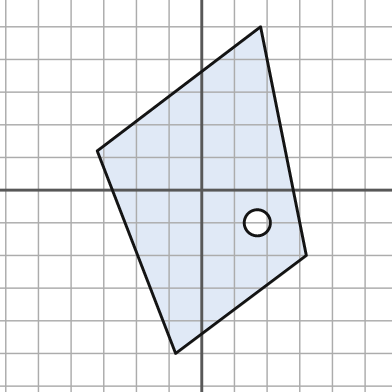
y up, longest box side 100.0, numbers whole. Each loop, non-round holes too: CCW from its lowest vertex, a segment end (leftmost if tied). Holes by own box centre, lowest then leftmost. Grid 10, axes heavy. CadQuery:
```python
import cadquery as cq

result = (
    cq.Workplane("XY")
    .moveTo(-8.0, -50.0)
    .lineTo(32.0, -20.0)
    .lineTo(18.0, 50.0)
    .lineTo(-32.0, 12.0)
    .close()
    .moveTo(17.0, -10.0)
    .circle(4.0)
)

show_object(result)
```